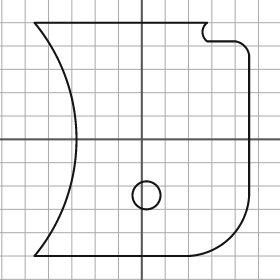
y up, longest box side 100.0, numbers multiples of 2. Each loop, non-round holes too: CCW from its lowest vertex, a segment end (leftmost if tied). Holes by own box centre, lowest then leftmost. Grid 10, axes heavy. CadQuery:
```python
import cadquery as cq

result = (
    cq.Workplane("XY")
    .moveTo(-46.0, -50.0)
    .lineTo(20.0, -50.0)
    .threePointArc((38.0, -42.0), (46.0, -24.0))
    .lineTo(46.0, 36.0)
    .threePointArc((44.0, 40.0), (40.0, 42.0))
    .lineTo(28.0, 42.0)
    .threePointArc((26.0, 46.0), (28.0, 50.0))
    .lineTo(-46.0, 50.0)
    .threePointArc((-28.0, 0.0), (-46.0, -50.0))
    .close()
    .moveTo(2.0, -24.0)
    .circle(6.0)
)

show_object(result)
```